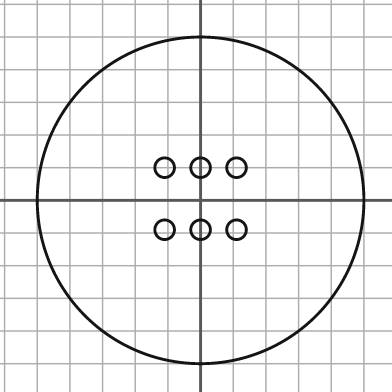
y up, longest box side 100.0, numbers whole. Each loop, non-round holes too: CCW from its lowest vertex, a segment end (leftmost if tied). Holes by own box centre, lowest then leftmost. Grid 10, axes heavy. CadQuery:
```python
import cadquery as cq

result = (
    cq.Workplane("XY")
    .moveTo(0.0, 0.0)
    .circle(50.0)
    .moveTo(-11.0, -9.0)
    .circle(3.0)
    .moveTo(0.0, -9.0)
    .circle(3.0)
    .moveTo(11.0, -9.0)
    .circle(3.0)
    .moveTo(-11.0, 10.0)
    .circle(3.0)
    .moveTo(0.0, 10.0)
    .circle(3.0)
    .moveTo(11.0, 10.0)
    .circle(3.0)
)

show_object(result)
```